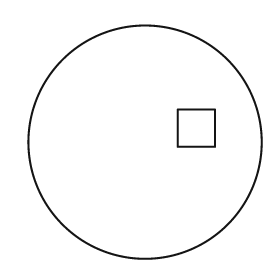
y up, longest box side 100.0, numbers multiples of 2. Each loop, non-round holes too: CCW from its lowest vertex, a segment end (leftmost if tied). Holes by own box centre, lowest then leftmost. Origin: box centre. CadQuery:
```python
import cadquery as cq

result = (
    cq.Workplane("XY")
    .moveTo(0.0, 0.0)
    .circle(50.0)
    .moveTo(14.0, -2.0)
    .lineTo(30.0, -2.0)
    .lineTo(30.0, 14.0)
    .lineTo(14.0, 14.0)
    .close()
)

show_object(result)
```